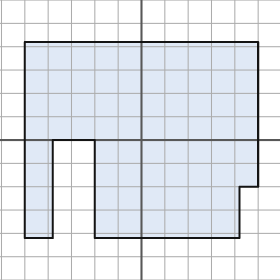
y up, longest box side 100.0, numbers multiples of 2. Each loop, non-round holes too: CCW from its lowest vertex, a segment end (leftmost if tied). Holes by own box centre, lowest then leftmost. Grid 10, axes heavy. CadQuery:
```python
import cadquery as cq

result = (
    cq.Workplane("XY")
    .moveTo(-50.0, -42.0)
    .lineTo(-38.0, -42.0)
    .lineTo(-38.0, 0.0)
    .lineTo(-20.0, 0.0)
    .lineTo(-20.0, -42.0)
    .lineTo(42.0, -42.0)
    .lineTo(42.0, -20.0)
    .lineTo(50.0, -20.0)
    .lineTo(50.0, 42.0)
    .lineTo(-50.0, 42.0)
    .close()
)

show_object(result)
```